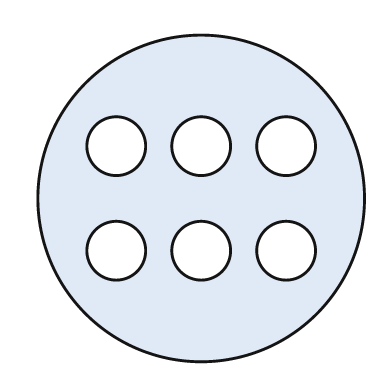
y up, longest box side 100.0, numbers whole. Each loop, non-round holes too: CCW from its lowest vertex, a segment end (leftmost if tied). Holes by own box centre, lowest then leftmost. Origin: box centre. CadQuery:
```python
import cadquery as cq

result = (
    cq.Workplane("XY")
    .moveTo(0.0, 0.0)
    .circle(50.0)
    .moveTo(-26.0, -16.0)
    .circle(9.0)
    .moveTo(0.0, -16.0)
    .circle(9.0)
    .moveTo(26.0, -16.0)
    .circle(9.0)
    .moveTo(-26.0, 16.0)
    .circle(9.0)
    .moveTo(0.0, 16.0)
    .circle(9.0)
    .moveTo(26.0, 16.0)
    .circle(9.0)
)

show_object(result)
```